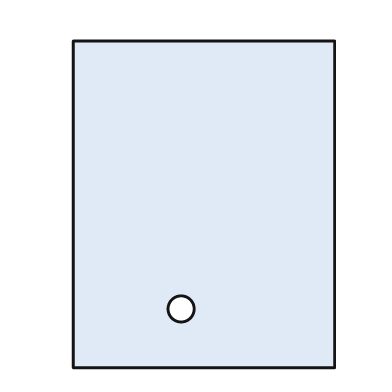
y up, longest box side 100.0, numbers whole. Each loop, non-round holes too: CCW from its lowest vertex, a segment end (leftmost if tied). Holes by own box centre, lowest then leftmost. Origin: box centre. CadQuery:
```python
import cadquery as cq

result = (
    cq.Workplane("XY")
    .moveTo(-40.0, -50.0)
    .lineTo(40.0, -50.0)
    .lineTo(40.0, 50.0)
    .lineTo(-40.0, 50.0)
    .close()
    .moveTo(-7.0, -32.0)
    .circle(4.0)
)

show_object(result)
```